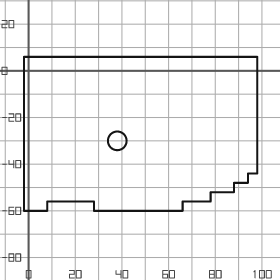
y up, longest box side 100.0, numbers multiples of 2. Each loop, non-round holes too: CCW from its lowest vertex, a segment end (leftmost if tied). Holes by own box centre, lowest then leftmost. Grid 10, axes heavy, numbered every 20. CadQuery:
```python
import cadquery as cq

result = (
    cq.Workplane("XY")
    .moveTo(-2.0, -60.0)
    .lineTo(8.0, -60.0)
    .lineTo(8.0, -56.0)
    .lineTo(28.0, -56.0)
    .lineTo(28.0, -60.0)
    .lineTo(66.0, -60.0)
    .lineTo(66.0, -56.0)
    .lineTo(78.0, -56.0)
    .lineTo(78.0, -52.0)
    .lineTo(88.0, -52.0)
    .lineTo(88.0, -48.0)
    .lineTo(94.0, -48.0)
    .lineTo(94.0, -44.0)
    .lineTo(98.0, -44.0)
    .lineTo(98.0, 6.0)
    .lineTo(-2.0, 6.0)
    .close()
    .moveTo(38.0, -30.0)
    .circle(4.0)
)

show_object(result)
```